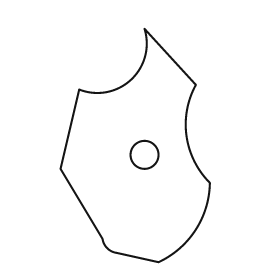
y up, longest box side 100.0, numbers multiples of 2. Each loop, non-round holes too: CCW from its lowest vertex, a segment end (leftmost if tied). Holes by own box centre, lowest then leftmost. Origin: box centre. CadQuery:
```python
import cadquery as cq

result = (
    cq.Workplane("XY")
    .moveTo(10.0, -50.0)
    .threePointArc((26.0, -36.0), (32.0, -16.0))
    .threePointArc((22.0, 4.0), (26.0, 26.0))
    .lineTo(4.0, 50.0)
    .threePointArc((-2.0, 28.0), (-24.0, 24.0))
    .lineTo(-32.0, -10.0)
    .lineTo(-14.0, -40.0)
    .threePointArc((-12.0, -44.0), (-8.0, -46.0))
    .close()
    .moveTo(4.0, -4.0)
    .circle(6.0)
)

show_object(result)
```